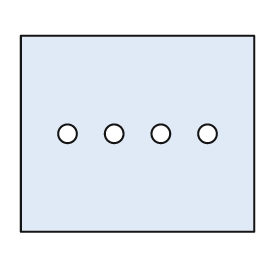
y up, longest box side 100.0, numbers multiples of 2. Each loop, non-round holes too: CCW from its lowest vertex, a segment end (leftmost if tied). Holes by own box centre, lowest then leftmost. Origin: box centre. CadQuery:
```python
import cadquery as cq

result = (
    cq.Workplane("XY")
    .moveTo(-50.0, -42.0)
    .lineTo(50.0, -42.0)
    .lineTo(50.0, 42.0)
    .lineTo(-50.0, 42.0)
    .close()
    .moveTo(-30.0, 0.0)
    .circle(4.0)
    .moveTo(-10.0, 0.0)
    .circle(4.0)
    .moveTo(10.0, 0.0)
    .circle(4.0)
    .moveTo(30.0, 0.0)
    .circle(4.0)
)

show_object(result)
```